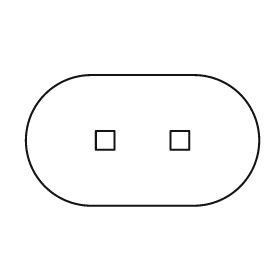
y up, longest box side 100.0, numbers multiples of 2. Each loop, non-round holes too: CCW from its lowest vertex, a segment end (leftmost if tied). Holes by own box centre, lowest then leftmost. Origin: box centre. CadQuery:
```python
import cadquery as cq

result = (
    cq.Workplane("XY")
    .moveTo(-22.0, -28.0)
    .lineTo(22.0, -28.0)
    .threePointArc((50.0, 0.0), (22.0, 28.0))
    .lineTo(-22.0, 28.0)
    .threePointArc((-50.0, 0.0), (-22.0, -28.0))
    .close()
    .moveTo(-20.0, -4.0)
    .lineTo(-12.0, -4.0)
    .lineTo(-12.0, 4.0)
    .lineTo(-20.0, 4.0)
    .close()
    .moveTo(12.0, -4.0)
    .lineTo(20.0, -4.0)
    .lineTo(20.0, 4.0)
    .lineTo(12.0, 4.0)
    .close()
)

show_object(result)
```